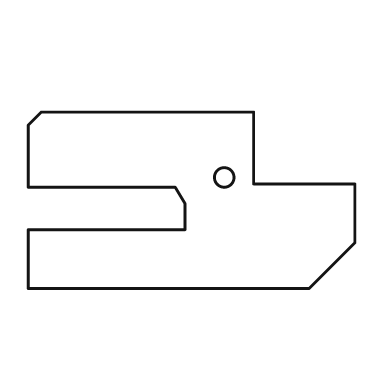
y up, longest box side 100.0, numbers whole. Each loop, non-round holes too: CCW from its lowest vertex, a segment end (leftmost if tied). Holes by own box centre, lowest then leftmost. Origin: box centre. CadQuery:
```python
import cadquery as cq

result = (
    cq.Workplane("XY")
    .moveTo(-50.0, -27.0)
    .lineTo(36.0, -27.0)
    .lineTo(50.0, -13.0)
    .lineTo(50.0, 5.0)
    .lineTo(19.0, 5.0)
    .lineTo(19.0, 27.0)
    .lineTo(-46.0, 27.0)
    .lineTo(-50.0, 23.0)
    .lineTo(-50.0, 4.0)
    .lineTo(-5.0, 4.0)
    .lineTo(-2.0, -1.0)
    .lineTo(-2.0, -9.0)
    .lineTo(-50.0, -9.0)
    .close()
    .moveTo(10.0, 7.0)
    .circle(3.0)
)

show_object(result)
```